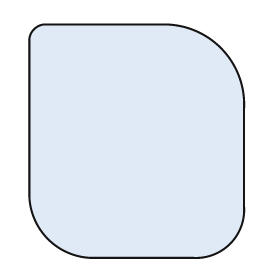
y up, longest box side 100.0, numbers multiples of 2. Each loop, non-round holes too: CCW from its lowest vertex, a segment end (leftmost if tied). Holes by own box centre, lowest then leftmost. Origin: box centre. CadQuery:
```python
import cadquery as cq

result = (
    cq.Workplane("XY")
    .moveTo(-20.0, -50.0)
    .lineTo(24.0, -50.0)
    .threePointArc((40.0, -44.0), (46.0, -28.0))
    .lineTo(46.0, 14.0)
    .threePointArc((36.0, 40.0), (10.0, 50.0))
    .lineTo(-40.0, 50.0)
    .threePointArc((-44.0, 48.0), (-46.0, 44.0))
    .lineTo(-46.0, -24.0)
    .threePointArc((-38.0, -42.0), (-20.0, -50.0))
    .close()
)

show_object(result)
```